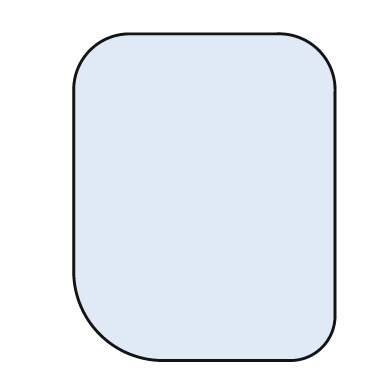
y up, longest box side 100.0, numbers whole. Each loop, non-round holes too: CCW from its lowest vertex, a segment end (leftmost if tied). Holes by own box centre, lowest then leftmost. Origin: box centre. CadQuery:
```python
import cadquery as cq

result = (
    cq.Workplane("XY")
    .moveTo(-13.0, -50.0)
    .lineTo(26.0, -50.0)
    .threePointArc((36.0, -46.0), (40.0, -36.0))
    .lineTo(40.0, 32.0)
    .threePointArc((35.0, 45.0), (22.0, 50.0))
    .lineTo(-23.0, 50.0)
    .threePointArc((-35.0, 45.0), (-40.0, 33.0))
    .lineTo(-40.0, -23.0)
    .threePointArc((-32.0, -42.0), (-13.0, -50.0))
    .close()
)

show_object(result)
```